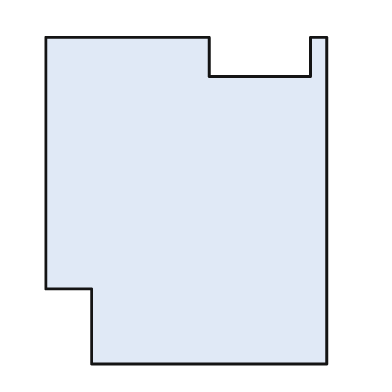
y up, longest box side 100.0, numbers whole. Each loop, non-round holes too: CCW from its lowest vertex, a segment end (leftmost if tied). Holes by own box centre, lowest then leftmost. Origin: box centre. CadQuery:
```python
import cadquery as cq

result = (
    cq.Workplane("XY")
    .moveTo(-29.0, -50.0)
    .lineTo(43.0, -50.0)
    .lineTo(43.0, 50.0)
    .lineTo(38.0, 50.0)
    .lineTo(38.0, 38.0)
    .lineTo(7.0, 38.0)
    .lineTo(7.0, 50.0)
    .lineTo(-43.0, 50.0)
    .lineTo(-43.0, -27.0)
    .lineTo(-29.0, -27.0)
    .close()
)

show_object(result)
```